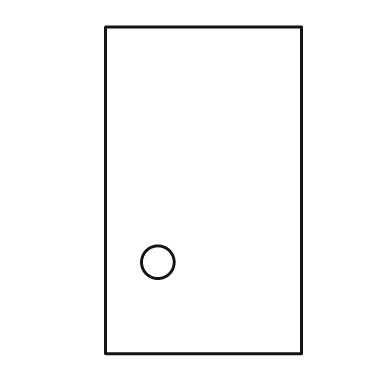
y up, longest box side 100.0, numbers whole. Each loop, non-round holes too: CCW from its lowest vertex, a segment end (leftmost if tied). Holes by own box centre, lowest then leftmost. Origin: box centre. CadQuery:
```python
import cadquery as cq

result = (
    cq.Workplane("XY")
    .moveTo(-30.0, -50.0)
    .lineTo(30.0, -50.0)
    .lineTo(30.0, 50.0)
    .lineTo(-30.0, 50.0)
    .close()
    .moveTo(-14.0, -22.0)
    .circle(5.0)
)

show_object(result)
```